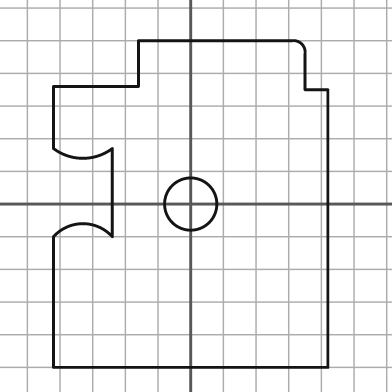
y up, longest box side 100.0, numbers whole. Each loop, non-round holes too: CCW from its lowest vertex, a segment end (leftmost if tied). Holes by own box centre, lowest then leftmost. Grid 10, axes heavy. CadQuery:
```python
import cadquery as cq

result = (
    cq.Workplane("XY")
    .moveTo(-42.0, -50.0)
    .lineTo(42.0, -50.0)
    .lineTo(42.0, 35.0)
    .lineTo(35.0, 35.0)
    .lineTo(35.0, 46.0)
    .threePointArc((34.0, 49.0), (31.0, 50.0))
    .lineTo(-16.0, 50.0)
    .lineTo(-16.0, 36.0)
    .lineTo(-42.0, 36.0)
    .lineTo(-42.0, 17.0)
    .threePointArc((-33.0, 14.0), (-24.0, 17.0))
    .lineTo(-24.0, -10.0)
    .threePointArc((-33.0, -6.0), (-42.0, -10.0))
    .close()
    .moveTo(0.0, 0.0)
    .circle(8.0)
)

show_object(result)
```